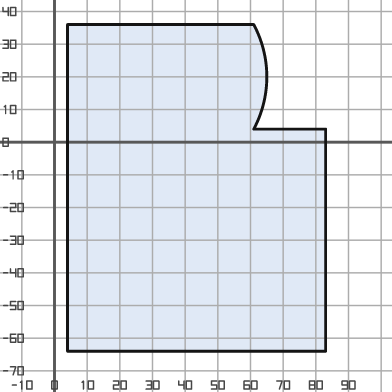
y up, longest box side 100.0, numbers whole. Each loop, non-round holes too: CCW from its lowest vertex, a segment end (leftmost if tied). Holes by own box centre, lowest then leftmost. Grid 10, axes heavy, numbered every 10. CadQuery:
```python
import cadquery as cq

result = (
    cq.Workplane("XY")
    .moveTo(4.0, -64.0)
    .lineTo(83.0, -64.0)
    .lineTo(83.0, 4.0)
    .lineTo(61.0, 4.0)
    .threePointArc((65.0, 20.0), (61.0, 36.0))
    .lineTo(4.0, 36.0)
    .close()
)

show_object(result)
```